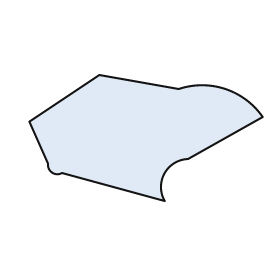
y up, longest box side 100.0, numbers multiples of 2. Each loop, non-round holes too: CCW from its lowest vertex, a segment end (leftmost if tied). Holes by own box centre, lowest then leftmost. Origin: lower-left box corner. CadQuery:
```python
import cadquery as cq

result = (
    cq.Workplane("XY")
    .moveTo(58.0, 0.0)
    .threePointArc((58.0, 12.0), (68.0, 18.0))
    .lineTo(100.0, 36.0)
    .threePointArc((84.0, 48.0), (64.0, 48.0))
    .lineTo(30.0, 54.0)
    .lineTo(0.0, 34.0)
    .lineTo(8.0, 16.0)
    .threePointArc((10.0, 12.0), (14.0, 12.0))
    .close()
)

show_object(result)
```